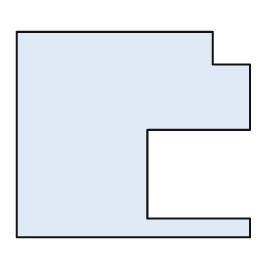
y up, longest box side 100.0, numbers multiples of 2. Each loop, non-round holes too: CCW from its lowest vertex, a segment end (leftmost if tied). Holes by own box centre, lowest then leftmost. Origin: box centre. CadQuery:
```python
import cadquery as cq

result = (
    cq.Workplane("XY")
    .moveTo(-50.0, -44.0)
    .lineTo(50.0, -44.0)
    .lineTo(50.0, -36.0)
    .lineTo(6.0, -36.0)
    .lineTo(6.0, 2.0)
    .lineTo(50.0, 2.0)
    .lineTo(50.0, 30.0)
    .lineTo(34.0, 30.0)
    .lineTo(34.0, 44.0)
    .lineTo(-50.0, 44.0)
    .close()
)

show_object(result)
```